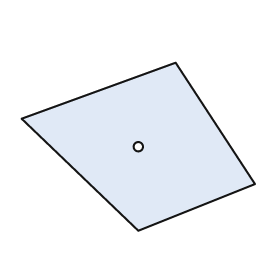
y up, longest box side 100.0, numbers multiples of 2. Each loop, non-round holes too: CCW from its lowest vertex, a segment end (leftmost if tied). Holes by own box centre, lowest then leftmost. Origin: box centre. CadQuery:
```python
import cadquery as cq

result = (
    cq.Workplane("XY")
    .moveTo(0.0, -36.0)
    .lineTo(50.0, -16.0)
    .lineTo(16.0, 36.0)
    .lineTo(-50.0, 12.0)
    .close()
    .moveTo(0.0, 0.0)
    .circle(2.0)
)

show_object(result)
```